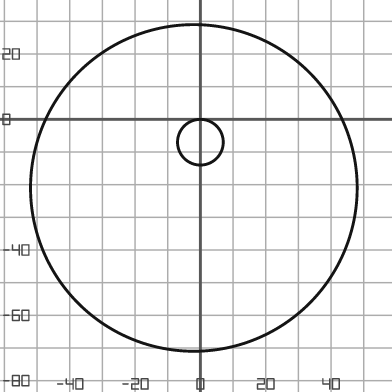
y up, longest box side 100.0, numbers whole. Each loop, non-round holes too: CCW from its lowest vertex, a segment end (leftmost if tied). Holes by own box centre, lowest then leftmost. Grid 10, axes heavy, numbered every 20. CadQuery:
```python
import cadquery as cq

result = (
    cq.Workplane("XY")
    .moveTo(-2.0, -21.0)
    .circle(50.0)
    .moveTo(0.0, -7.0)
    .circle(7.0)
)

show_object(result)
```